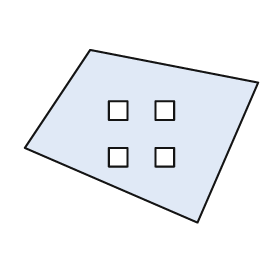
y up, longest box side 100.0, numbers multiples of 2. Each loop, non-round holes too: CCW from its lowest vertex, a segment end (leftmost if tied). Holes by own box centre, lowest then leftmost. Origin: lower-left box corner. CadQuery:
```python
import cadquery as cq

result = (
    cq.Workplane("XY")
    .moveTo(74.0, 0.0)
    .lineTo(100.0, 60.0)
    .lineTo(28.0, 74.0)
    .lineTo(0.0, 32.0)
    .close()
    .moveTo(36.0, 24.0)
    .lineTo(44.0, 24.0)
    .lineTo(44.0, 32.0)
    .lineTo(36.0, 32.0)
    .close()
    .moveTo(56.0, 24.0)
    .lineTo(64.0, 24.0)
    .lineTo(64.0, 32.0)
    .lineTo(56.0, 32.0)
    .close()
    .moveTo(36.0, 44.0)
    .lineTo(44.0, 44.0)
    .lineTo(44.0, 52.0)
    .lineTo(36.0, 52.0)
    .close()
    .moveTo(56.0, 44.0)
    .lineTo(64.0, 44.0)
    .lineTo(64.0, 52.0)
    .lineTo(56.0, 52.0)
    .close()
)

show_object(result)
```